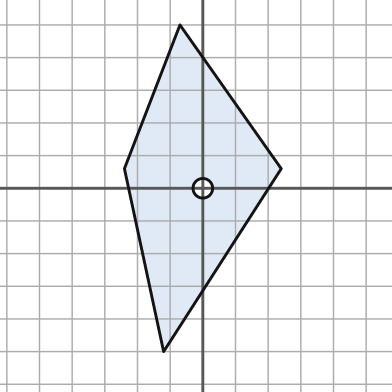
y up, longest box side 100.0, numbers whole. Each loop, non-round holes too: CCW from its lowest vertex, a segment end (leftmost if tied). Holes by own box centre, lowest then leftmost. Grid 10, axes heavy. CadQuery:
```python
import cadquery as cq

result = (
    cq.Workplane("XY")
    .moveTo(-12.0, -50.0)
    .lineTo(24.0, 6.0)
    .lineTo(-7.0, 50.0)
    .lineTo(-24.0, 6.0)
    .close()
    .moveTo(0.0, 0.0)
    .circle(3.0)
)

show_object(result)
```